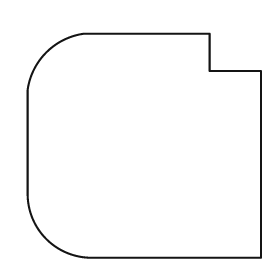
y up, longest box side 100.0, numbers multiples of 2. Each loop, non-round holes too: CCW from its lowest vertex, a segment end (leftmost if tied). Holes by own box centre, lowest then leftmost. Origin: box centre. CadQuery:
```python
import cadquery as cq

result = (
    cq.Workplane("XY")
    .moveTo(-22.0, -48.0)
    .lineTo(50.0, -48.0)
    .lineTo(50.0, 32.0)
    .lineTo(28.0, 32.0)
    .lineTo(28.0, 48.0)
    .lineTo(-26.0, 48.0)
    .threePointArc((-42.0, 40.0), (-50.0, 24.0))
    .lineTo(-50.0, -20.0)
    .threePointArc((-42.0, -40.0), (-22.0, -48.0))
    .close()
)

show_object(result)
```